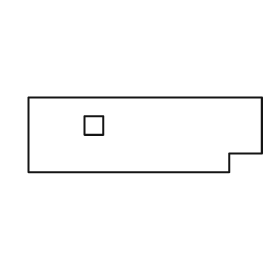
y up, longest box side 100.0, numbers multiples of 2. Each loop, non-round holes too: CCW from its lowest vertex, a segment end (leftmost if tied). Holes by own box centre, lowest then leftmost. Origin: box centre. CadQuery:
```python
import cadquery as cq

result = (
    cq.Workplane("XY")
    .moveTo(-50.0, -16.0)
    .lineTo(36.0, -16.0)
    .lineTo(36.0, -8.0)
    .lineTo(50.0, -8.0)
    .lineTo(50.0, 16.0)
    .lineTo(-50.0, 16.0)
    .close()
    .moveTo(-26.0, 0.0)
    .lineTo(-18.0, 0.0)
    .lineTo(-18.0, 8.0)
    .lineTo(-26.0, 8.0)
    .close()
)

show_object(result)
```